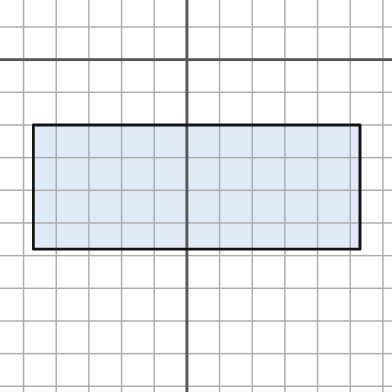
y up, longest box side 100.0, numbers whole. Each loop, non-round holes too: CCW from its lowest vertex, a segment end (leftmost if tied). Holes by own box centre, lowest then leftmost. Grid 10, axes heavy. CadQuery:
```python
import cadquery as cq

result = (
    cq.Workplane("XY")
    .moveTo(-47.0, -58.0)
    .lineTo(53.0, -58.0)
    .lineTo(53.0, -20.0)
    .lineTo(-47.0, -20.0)
    .close()
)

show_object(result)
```